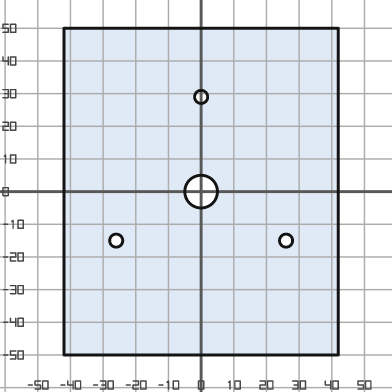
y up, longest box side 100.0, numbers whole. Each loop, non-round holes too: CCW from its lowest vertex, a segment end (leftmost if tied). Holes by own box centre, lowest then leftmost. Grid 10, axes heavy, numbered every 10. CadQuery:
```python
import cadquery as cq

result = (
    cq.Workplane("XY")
    .moveTo(-42.0, -50.0)
    .lineTo(42.0, -50.0)
    .lineTo(42.0, 50.0)
    .lineTo(-42.0, 50.0)
    .close()
    .moveTo(-26.0, -15.0)
    .circle(2.0)
    .moveTo(26.0, -15.0)
    .circle(2.0)
    .moveTo(0.0, 0.0)
    .circle(5.0)
    .moveTo(0.0, 29.0)
    .circle(2.0)
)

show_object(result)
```